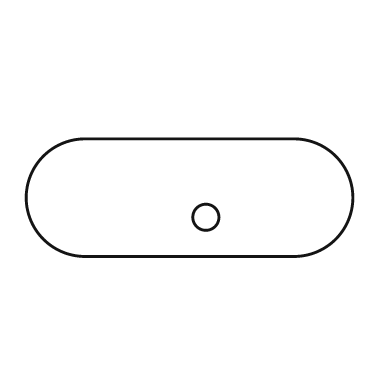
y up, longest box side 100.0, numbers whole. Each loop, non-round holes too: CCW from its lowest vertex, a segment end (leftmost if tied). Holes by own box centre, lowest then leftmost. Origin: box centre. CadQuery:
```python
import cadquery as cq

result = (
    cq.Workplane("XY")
    .moveTo(-32.0, -18.0)
    .lineTo(32.0, -18.0)
    .threePointArc((50.0, 0.0), (32.0, 18.0))
    .lineTo(-32.0, 18.0)
    .threePointArc((-50.0, 0.0), (-32.0, -18.0))
    .close()
    .moveTo(5.0, -6.0)
    .circle(4.0)
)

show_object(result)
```